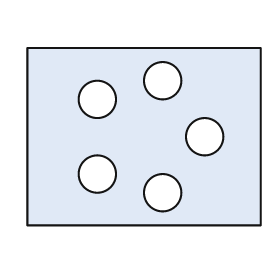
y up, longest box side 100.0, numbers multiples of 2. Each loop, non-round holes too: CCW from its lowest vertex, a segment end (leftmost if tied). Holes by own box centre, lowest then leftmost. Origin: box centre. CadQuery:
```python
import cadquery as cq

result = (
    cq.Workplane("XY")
    .moveTo(-50.0, -38.0)
    .lineTo(50.0, -38.0)
    .lineTo(50.0, 38.0)
    .lineTo(-50.0, 38.0)
    .close()
    .moveTo(8.0, -24.0)
    .circle(8.0)
    .moveTo(-20.0, -16.0)
    .circle(8.0)
    .moveTo(26.0, 0.0)
    .circle(8.0)
    .moveTo(-20.0, 16.0)
    .circle(8.0)
    .moveTo(8.0, 24.0)
    .circle(8.0)
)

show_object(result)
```